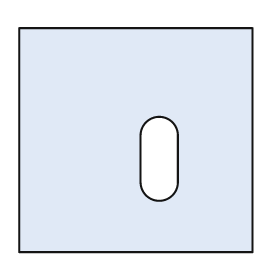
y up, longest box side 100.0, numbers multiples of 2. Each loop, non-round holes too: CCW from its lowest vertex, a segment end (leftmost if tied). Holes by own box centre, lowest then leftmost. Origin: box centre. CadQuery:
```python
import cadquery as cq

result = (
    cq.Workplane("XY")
    .moveTo(-50.0, -48.0)
    .lineTo(50.0, -48.0)
    .lineTo(50.0, 48.0)
    .lineTo(-50.0, 48.0)
    .close()
    .moveTo(2.0, -18.0)
    .threePointArc((10.0, -26.0), (18.0, -18.0))
    .lineTo(18.0, 2.0)
    .threePointArc((10.0, 10.0), (2.0, 2.0))
    .close()
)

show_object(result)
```